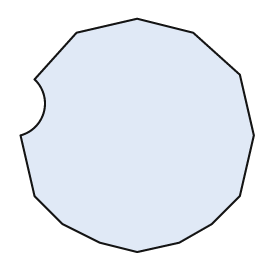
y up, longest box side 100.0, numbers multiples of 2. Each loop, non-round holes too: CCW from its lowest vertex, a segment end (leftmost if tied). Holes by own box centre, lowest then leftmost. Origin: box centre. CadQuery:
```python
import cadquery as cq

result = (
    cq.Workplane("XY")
    .moveTo(0.0, -50.0)
    .lineTo(18.0, -46.0)
    .lineTo(32.0, -38.0)
    .lineTo(44.0, -26.0)
    .lineTo(50.0, 0.0)
    .lineTo(44.0, 26.0)
    .lineTo(24.0, 44.0)
    .lineTo(0.0, 50.0)
    .lineTo(-26.0, 44.0)
    .lineTo(-44.0, 24.0)
    .threePointArc((-40.0, 10.0), (-50.0, 0.0))
    .lineTo(-44.0, -26.0)
    .lineTo(-32.0, -38.0)
    .lineTo(-16.0, -46.0)
    .close()
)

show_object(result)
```